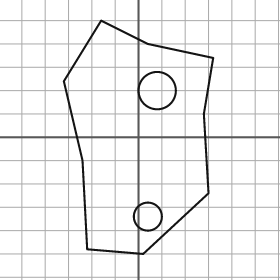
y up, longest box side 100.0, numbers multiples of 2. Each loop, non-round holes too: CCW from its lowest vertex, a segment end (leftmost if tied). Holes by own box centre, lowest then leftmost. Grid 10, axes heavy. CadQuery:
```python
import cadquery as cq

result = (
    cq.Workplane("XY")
    .moveTo(2.0, -50.0)
    .lineTo(30.0, -24.0)
    .lineTo(28.0, 10.0)
    .lineTo(32.0, 34.0)
    .lineTo(4.0, 40.0)
    .lineTo(-16.0, 50.0)
    .lineTo(-32.0, 24.0)
    .lineTo(-24.0, -10.0)
    .lineTo(-22.0, -48.0)
    .close()
    .moveTo(4.0, -34.0)
    .circle(6.0)
    .moveTo(8.0, 20.0)
    .circle(8.0)
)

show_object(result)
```